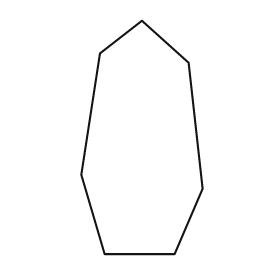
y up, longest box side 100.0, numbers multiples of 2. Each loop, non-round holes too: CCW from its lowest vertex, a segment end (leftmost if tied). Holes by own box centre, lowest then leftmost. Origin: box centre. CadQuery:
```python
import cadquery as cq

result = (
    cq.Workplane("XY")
    .moveTo(-16.0, -50.0)
    .lineTo(14.0, -50.0)
    .lineTo(26.0, -22.0)
    .lineTo(20.0, 32.0)
    .lineTo(0.0, 50.0)
    .lineTo(-18.0, 36.0)
    .lineTo(-26.0, -16.0)
    .close()
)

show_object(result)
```